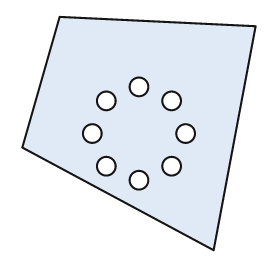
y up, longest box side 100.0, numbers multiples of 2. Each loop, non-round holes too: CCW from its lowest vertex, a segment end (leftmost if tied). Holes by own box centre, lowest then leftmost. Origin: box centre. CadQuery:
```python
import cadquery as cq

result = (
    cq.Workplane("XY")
    .moveTo(32.0, -50.0)
    .lineTo(50.0, 46.0)
    .lineTo(-34.0, 50.0)
    .lineTo(-50.0, -6.0)
    .close()
    .moveTo(0.0, -20.0)
    .circle(4.0)
    .moveTo(-14.0, -14.0)
    .circle(4.0)
    .moveTo(14.0, -14.0)
    .circle(4.0)
    .moveTo(-20.0, 0.0)
    .circle(4.0)
    .moveTo(20.0, 0.0)
    .circle(4.0)
    .moveTo(-14.0, 14.0)
    .circle(4.0)
    .moveTo(14.0, 14.0)
    .circle(4.0)
    .moveTo(0.0, 20.0)
    .circle(4.0)
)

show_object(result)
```